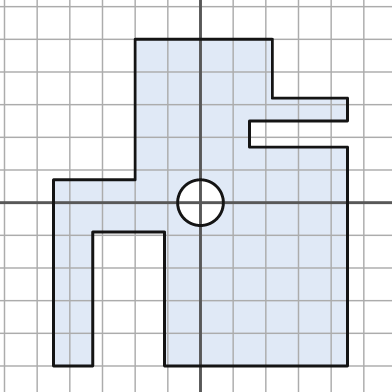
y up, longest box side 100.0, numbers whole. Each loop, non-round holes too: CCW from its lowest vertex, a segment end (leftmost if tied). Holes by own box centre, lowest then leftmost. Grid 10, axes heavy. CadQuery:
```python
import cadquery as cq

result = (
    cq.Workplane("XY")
    .moveTo(-45.0, -50.0)
    .lineTo(-33.0, -50.0)
    .lineTo(-33.0, -9.0)
    .lineTo(-11.0, -9.0)
    .lineTo(-11.0, -50.0)
    .lineTo(45.0, -50.0)
    .lineTo(45.0, 17.0)
    .lineTo(15.0, 17.0)
    .lineTo(15.0, 25.0)
    .lineTo(45.0, 25.0)
    .lineTo(45.0, 32.0)
    .lineTo(22.0, 32.0)
    .lineTo(22.0, 50.0)
    .lineTo(-20.0, 50.0)
    .lineTo(-20.0, 7.0)
    .lineTo(-45.0, 7.0)
    .close()
    .moveTo(0.0, 0.0)
    .circle(7.0)
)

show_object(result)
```